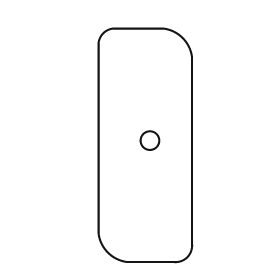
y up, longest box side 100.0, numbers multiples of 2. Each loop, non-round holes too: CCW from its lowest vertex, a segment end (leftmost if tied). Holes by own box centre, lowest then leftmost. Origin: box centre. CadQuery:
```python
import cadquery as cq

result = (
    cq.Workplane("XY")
    .moveTo(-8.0, -50.0)
    .lineTo(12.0, -50.0)
    .threePointArc((18.0, -48.0), (20.0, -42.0))
    .lineTo(20.0, 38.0)
    .threePointArc((16.0, 46.0), (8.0, 50.0))
    .lineTo(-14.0, 50.0)
    .threePointArc((-18.0, 48.0), (-20.0, 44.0))
    .lineTo(-20.0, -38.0)
    .threePointArc((-16.0, -46.0), (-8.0, -50.0))
    .close()
    .moveTo(2.0, 2.0)
    .circle(4.0)
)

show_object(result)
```